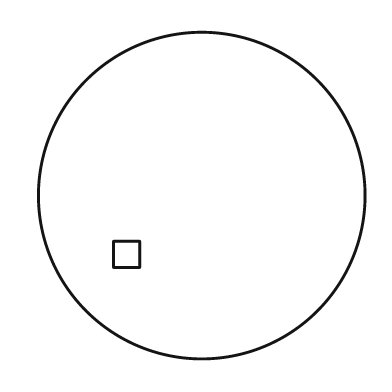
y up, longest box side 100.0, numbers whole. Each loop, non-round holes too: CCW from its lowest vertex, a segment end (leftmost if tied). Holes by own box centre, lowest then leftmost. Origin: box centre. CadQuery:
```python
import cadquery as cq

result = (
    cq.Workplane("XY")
    .moveTo(0.0, 0.0)
    .circle(50.0)
    .moveTo(-27.0, -22.0)
    .lineTo(-19.0, -22.0)
    .lineTo(-19.0, -14.0)
    .lineTo(-27.0, -14.0)
    .close()
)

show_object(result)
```